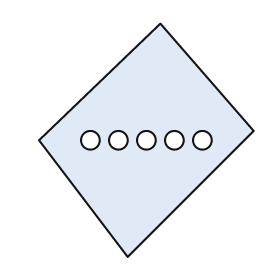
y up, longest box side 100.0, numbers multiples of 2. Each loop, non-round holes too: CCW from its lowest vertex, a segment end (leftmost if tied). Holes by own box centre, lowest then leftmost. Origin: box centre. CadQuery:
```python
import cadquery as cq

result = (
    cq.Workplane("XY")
    .moveTo(-8.0, -50.0)
    .lineTo(46.0, 4.0)
    .lineTo(6.0, 50.0)
    .lineTo(-46.0, 0.0)
    .close()
    .moveTo(-24.0, 0.0)
    .circle(4.0)
    .moveTo(-12.0, 0.0)
    .circle(4.0)
    .moveTo(0.0, 0.0)
    .circle(4.0)
    .moveTo(12.0, 0.0)
    .circle(4.0)
    .moveTo(24.0, 0.0)
    .circle(4.0)
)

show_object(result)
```